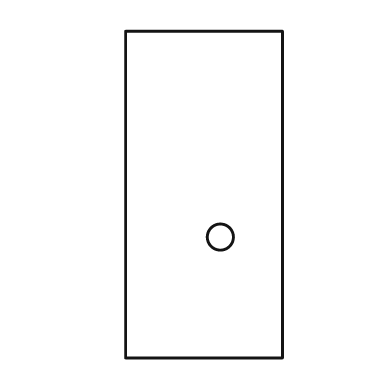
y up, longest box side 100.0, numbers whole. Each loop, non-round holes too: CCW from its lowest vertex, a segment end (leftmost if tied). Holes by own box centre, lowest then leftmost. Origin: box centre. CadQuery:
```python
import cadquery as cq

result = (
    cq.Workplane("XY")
    .moveTo(-24.0, -50.0)
    .lineTo(24.0, -50.0)
    .lineTo(24.0, 50.0)
    .lineTo(-24.0, 50.0)
    .close()
    .moveTo(5.0, -13.0)
    .circle(4.0)
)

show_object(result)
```